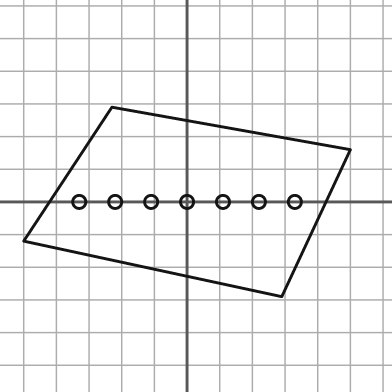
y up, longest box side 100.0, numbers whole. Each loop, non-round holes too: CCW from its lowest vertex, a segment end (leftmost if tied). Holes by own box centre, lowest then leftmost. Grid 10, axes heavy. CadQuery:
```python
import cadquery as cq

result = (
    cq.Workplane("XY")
    .moveTo(29.0, -29.0)
    .lineTo(50.0, 16.0)
    .lineTo(-23.0, 29.0)
    .lineTo(-50.0, -12.0)
    .close()
    .moveTo(-33.0, 0.0)
    .circle(2.0)
    .moveTo(-22.0, 0.0)
    .circle(2.0)
    .moveTo(-11.0, 0.0)
    .circle(2.0)
    .moveTo(0.0, 0.0)
    .circle(2.0)
    .moveTo(11.0, 0.0)
    .circle(2.0)
    .moveTo(22.0, 0.0)
    .circle(2.0)
    .moveTo(33.0, 0.0)
    .circle(2.0)
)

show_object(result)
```